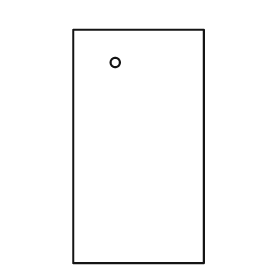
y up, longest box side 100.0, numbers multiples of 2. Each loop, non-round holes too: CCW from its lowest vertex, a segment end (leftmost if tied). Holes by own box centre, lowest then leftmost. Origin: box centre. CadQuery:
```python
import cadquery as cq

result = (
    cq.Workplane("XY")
    .moveTo(-28.0, -50.0)
    .lineTo(28.0, -50.0)
    .lineTo(28.0, 50.0)
    .lineTo(-28.0, 50.0)
    .close()
    .moveTo(-10.0, 36.0)
    .circle(2.0)
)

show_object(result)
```